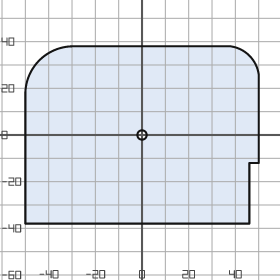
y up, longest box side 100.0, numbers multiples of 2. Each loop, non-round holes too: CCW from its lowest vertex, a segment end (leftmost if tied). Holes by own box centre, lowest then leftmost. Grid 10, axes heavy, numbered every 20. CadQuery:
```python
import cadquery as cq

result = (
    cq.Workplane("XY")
    .moveTo(-50.0, -38.0)
    .lineTo(46.0, -38.0)
    .lineTo(46.0, -12.0)
    .lineTo(50.0, -12.0)
    .lineTo(50.0, 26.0)
    .threePointArc((46.0, 34.0), (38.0, 38.0))
    .lineTo(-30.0, 38.0)
    .threePointArc((-44.0, 32.0), (-50.0, 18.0))
    .close()
    .moveTo(0.0, 0.0)
    .circle(2.0)
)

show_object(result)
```